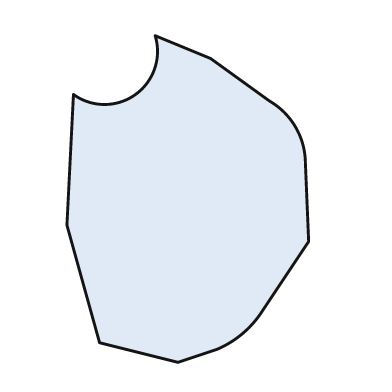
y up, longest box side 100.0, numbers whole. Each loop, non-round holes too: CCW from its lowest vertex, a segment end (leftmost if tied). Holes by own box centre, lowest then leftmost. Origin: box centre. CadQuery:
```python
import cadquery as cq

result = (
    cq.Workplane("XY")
    .moveTo(-3.0, -50.0)
    .lineTo(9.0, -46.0)
    .threePointArc((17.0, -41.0), (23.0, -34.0))
    .lineTo(37.0, -13.0)
    .lineTo(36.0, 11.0)
    .threePointArc((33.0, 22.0), (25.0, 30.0))
    .lineTo(7.0, 43.0)
    .lineTo(-10.0, 50.0)
    .threePointArc((-16.0, 32.0), (-35.0, 32.0))
    .lineTo(-37.0, -8.0)
    .lineTo(-27.0, -44.0)
    .close()
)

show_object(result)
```